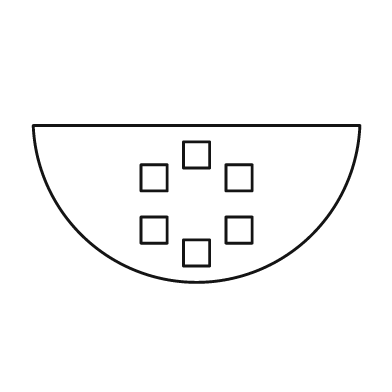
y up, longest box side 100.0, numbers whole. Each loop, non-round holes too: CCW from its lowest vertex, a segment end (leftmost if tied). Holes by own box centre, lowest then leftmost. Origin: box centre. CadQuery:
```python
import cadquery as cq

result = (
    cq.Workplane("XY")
    .moveTo(-50.0, 24.0)
    .threePointArc((0.0, -24.0), (50.0, 24.0))
    .close()
    .moveTo(-4.0, -19.0)
    .lineTo(4.0, -19.0)
    .lineTo(4.0, -11.0)
    .lineTo(-4.0, -11.0)
    .close()
    .moveTo(-17.0, -12.0)
    .lineTo(-9.0, -12.0)
    .lineTo(-9.0, -4.0)
    .lineTo(-17.0, -4.0)
    .close()
    .moveTo(9.0, -12.0)
    .lineTo(17.0, -12.0)
    .lineTo(17.0, -4.0)
    .lineTo(9.0, -4.0)
    .close()
    .moveTo(-17.0, 4.0)
    .lineTo(-9.0, 4.0)
    .lineTo(-9.0, 12.0)
    .lineTo(-17.0, 12.0)
    .close()
    .moveTo(9.0, 4.0)
    .lineTo(17.0, 4.0)
    .lineTo(17.0, 12.0)
    .lineTo(9.0, 12.0)
    .close()
    .moveTo(-4.0, 11.0)
    .lineTo(4.0, 11.0)
    .lineTo(4.0, 19.0)
    .lineTo(-4.0, 19.0)
    .close()
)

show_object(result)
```